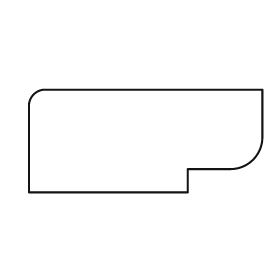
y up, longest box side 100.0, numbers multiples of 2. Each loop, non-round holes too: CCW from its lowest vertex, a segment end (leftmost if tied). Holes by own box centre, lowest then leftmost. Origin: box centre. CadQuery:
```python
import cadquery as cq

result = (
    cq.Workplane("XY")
    .moveTo(-50.0, -22.0)
    .lineTo(18.0, -22.0)
    .lineTo(18.0, -12.0)
    .lineTo(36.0, -12.0)
    .threePointArc((46.0, -8.0), (50.0, 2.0))
    .lineTo(50.0, 22.0)
    .lineTo(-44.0, 22.0)
    .threePointArc((-48.0, 20.0), (-50.0, 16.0))
    .close()
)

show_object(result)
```